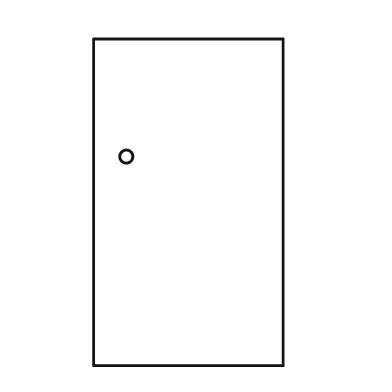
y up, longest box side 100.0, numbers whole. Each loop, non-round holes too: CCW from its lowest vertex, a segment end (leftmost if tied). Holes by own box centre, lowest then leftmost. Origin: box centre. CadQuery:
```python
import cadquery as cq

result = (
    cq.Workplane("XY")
    .moveTo(-29.0, -50.0)
    .lineTo(29.0, -50.0)
    .lineTo(29.0, 50.0)
    .lineTo(-29.0, 50.0)
    .close()
    .moveTo(-19.0, 14.0)
    .circle(2.0)
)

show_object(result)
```